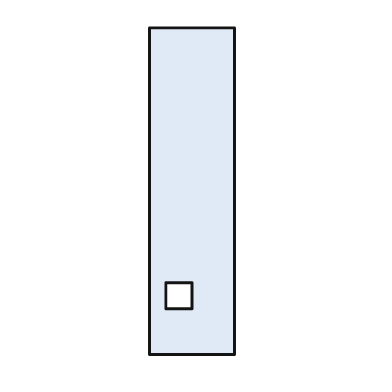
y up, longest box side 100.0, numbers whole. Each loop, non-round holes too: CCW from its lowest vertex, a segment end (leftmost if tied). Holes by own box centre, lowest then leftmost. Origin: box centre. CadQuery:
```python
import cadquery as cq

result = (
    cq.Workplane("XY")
    .moveTo(-13.0, -50.0)
    .lineTo(13.0, -50.0)
    .lineTo(13.0, 50.0)
    .lineTo(-13.0, 50.0)
    .close()
    .moveTo(-8.0, -36.0)
    .lineTo(0.0, -36.0)
    .lineTo(0.0, -28.0)
    .lineTo(-8.0, -28.0)
    .close()
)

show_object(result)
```